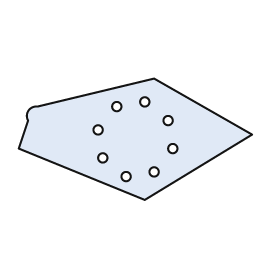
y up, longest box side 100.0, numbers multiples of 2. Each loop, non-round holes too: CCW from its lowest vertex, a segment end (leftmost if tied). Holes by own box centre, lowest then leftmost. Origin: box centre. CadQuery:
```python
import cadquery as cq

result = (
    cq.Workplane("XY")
    .moveTo(4.0, -26.0)
    .lineTo(50.0, 2.0)
    .lineTo(8.0, 26.0)
    .lineTo(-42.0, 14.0)
    .threePointArc((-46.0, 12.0), (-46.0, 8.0))
    .lineTo(-50.0, -4.0)
    .close()
    .moveTo(-4.0, -16.0)
    .circle(2.0)
    .moveTo(8.0, -14.0)
    .circle(2.0)
    .moveTo(-14.0, -8.0)
    .circle(2.0)
    .moveTo(16.0, -4.0)
    .circle(2.0)
    .moveTo(-16.0, 4.0)
    .circle(2.0)
    .moveTo(14.0, 8.0)
    .circle(2.0)
    .moveTo(-8.0, 14.0)
    .circle(2.0)
    .moveTo(4.0, 16.0)
    .circle(2.0)
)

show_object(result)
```